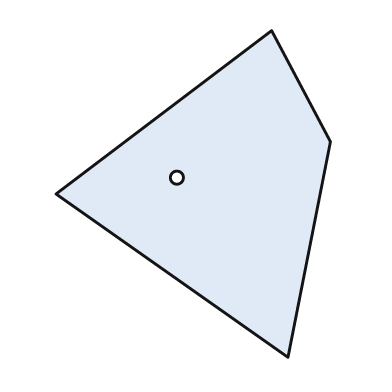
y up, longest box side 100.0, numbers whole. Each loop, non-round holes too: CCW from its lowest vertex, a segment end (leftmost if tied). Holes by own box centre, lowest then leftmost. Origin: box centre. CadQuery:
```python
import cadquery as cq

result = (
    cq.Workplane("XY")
    .moveTo(29.0, -50.0)
    .lineTo(42.0, 16.0)
    .lineTo(24.0, 50.0)
    .lineTo(-42.0, 0.0)
    .close()
    .moveTo(-5.0, 5.0)
    .circle(2.0)
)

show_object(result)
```